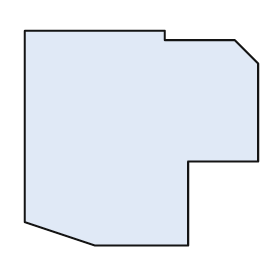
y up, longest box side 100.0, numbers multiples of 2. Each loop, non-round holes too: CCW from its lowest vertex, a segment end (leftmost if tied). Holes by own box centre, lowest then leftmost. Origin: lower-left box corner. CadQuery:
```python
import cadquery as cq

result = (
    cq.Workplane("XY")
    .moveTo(30.0, 0.0)
    .lineTo(70.0, 0.0)
    .lineTo(70.0, 36.0)
    .lineTo(100.0, 36.0)
    .lineTo(100.0, 78.0)
    .lineTo(90.0, 88.0)
    .lineTo(60.0, 88.0)
    .lineTo(60.0, 92.0)
    .lineTo(0.0, 92.0)
    .lineTo(0.0, 10.0)
    .close()
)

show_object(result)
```